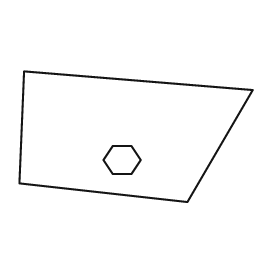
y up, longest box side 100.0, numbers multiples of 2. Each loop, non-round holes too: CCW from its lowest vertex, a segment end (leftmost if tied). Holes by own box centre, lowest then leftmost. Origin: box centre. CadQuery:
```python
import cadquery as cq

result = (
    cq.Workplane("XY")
    .moveTo(22.0, -28.0)
    .lineTo(50.0, 20.0)
    .lineTo(-48.0, 28.0)
    .lineTo(-50.0, -20.0)
    .close()
    .moveTo(-10.0, -16.0)
    .lineTo(-2.0, -16.0)
    .lineTo(2.0, -10.0)
    .lineTo(-2.0, -4.0)
    .lineTo(-10.0, -4.0)
    .lineTo(-14.0, -10.0)
    .close()
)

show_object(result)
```